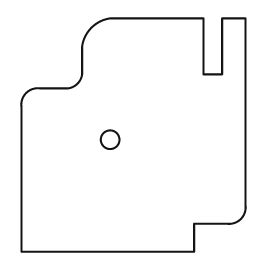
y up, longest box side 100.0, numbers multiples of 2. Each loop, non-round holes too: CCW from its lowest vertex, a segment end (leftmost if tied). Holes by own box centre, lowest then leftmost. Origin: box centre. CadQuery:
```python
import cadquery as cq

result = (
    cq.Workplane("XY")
    .moveTo(-48.0, -50.0)
    .lineTo(26.0, -50.0)
    .lineTo(26.0, -38.0)
    .lineTo(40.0, -38.0)
    .threePointArc((46.0, -36.0), (48.0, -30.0))
    .lineTo(48.0, 50.0)
    .lineTo(38.0, 50.0)
    .lineTo(38.0, 26.0)
    .lineTo(30.0, 26.0)
    .lineTo(30.0, 50.0)
    .lineTo(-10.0, 50.0)
    .threePointArc((-18.0, 46.0), (-22.0, 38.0))
    .lineTo(-22.0, 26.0)
    .threePointArc((-24.0, 22.0), (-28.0, 20.0))
    .lineTo(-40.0, 20.0)
    .threePointArc((-46.0, 18.0), (-48.0, 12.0))
    .close()
    .moveTo(-10.0, -2.0)
    .circle(4.0)
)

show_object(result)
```